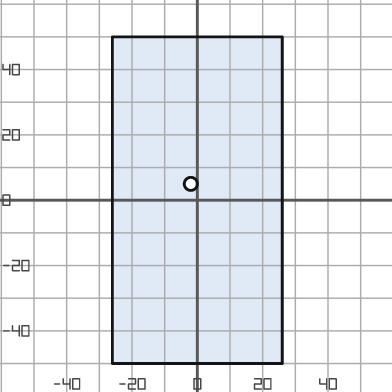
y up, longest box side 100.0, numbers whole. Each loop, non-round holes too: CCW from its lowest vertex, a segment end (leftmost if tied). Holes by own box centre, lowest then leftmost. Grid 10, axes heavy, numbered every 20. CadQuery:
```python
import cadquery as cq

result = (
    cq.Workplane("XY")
    .moveTo(-26.0, -50.0)
    .lineTo(26.0, -50.0)
    .lineTo(26.0, 50.0)
    .lineTo(-26.0, 50.0)
    .close()
    .moveTo(-2.0, 5.0)
    .circle(2.0)
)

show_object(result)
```